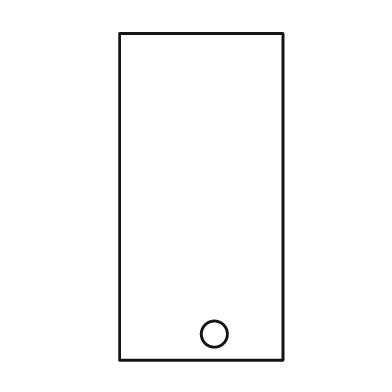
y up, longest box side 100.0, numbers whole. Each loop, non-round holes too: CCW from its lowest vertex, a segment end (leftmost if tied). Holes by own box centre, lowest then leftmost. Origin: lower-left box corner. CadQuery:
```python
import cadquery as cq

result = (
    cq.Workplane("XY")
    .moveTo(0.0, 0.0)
    .lineTo(50.0, 0.0)
    .lineTo(50.0, 100.0)
    .lineTo(0.0, 100.0)
    .close()
    .moveTo(29.0, 8.0)
    .circle(4.0)
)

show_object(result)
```